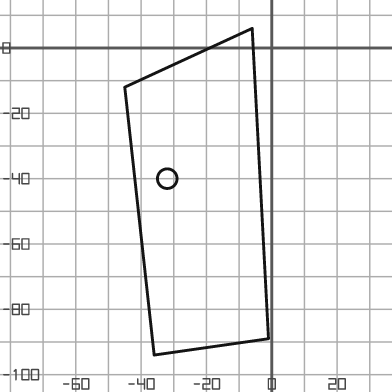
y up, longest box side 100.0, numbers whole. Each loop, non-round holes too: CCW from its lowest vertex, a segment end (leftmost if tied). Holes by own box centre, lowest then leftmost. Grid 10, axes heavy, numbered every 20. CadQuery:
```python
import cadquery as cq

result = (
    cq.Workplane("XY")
    .moveTo(-36.0, -94.0)
    .lineTo(-1.0, -89.0)
    .lineTo(-6.0, 6.0)
    .lineTo(-45.0, -12.0)
    .close()
    .moveTo(-32.0, -40.0)
    .circle(3.0)
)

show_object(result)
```